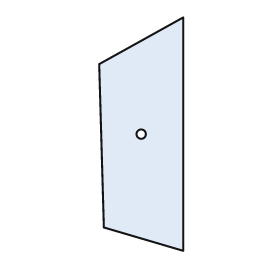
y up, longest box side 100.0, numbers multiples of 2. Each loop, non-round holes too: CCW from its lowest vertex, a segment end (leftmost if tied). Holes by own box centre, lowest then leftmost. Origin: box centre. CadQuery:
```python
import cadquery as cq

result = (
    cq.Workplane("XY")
    .moveTo(18.0, -50.0)
    .lineTo(18.0, 50.0)
    .lineTo(-18.0, 30.0)
    .lineTo(-16.0, -40.0)
    .close()
    .moveTo(0.0, 0.0)
    .circle(2.0)
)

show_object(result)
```